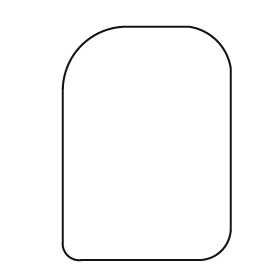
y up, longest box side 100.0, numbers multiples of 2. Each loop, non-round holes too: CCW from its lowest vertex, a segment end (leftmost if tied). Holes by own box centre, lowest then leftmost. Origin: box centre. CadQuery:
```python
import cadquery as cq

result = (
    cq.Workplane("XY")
    .moveTo(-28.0, -50.0)
    .lineTo(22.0, -50.0)
    .threePointArc((32.0, -46.0), (36.0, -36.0))
    .lineTo(36.0, 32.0)
    .threePointArc((30.0, 44.0), (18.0, 50.0))
    .lineTo(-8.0, 50.0)
    .threePointArc((-28.0, 42.0), (-36.0, 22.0))
    .lineTo(-36.0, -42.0)
    .threePointArc((-34.0, -48.0), (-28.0, -50.0))
    .close()
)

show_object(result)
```